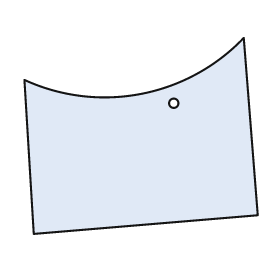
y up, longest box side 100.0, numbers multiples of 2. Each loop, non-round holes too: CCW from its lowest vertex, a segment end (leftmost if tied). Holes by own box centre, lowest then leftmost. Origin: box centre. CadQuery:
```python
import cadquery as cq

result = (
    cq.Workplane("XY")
    .moveTo(-46.0, -42.0)
    .lineTo(50.0, -34.0)
    .lineTo(44.0, 42.0)
    .threePointArc((0.0, 18.0), (-50.0, 24.0))
    .close()
    .moveTo(14.0, 14.0)
    .circle(2.0)
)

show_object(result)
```